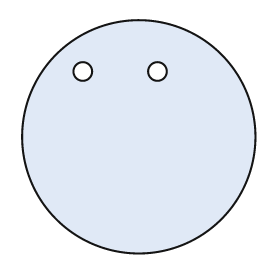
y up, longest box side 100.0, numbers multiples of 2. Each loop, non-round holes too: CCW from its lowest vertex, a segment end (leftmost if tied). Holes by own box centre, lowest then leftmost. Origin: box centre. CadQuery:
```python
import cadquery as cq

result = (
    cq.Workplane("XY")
    .moveTo(0.0, 0.0)
    .circle(50.0)
    .moveTo(-24.0, 28.0)
    .circle(4.0)
    .moveTo(8.0, 28.0)
    .circle(4.0)
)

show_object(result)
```